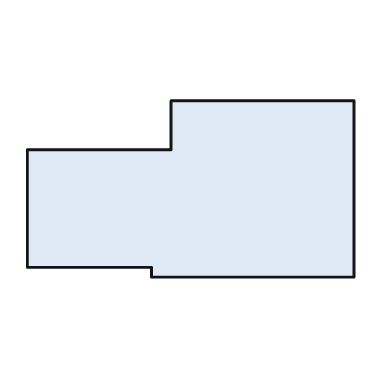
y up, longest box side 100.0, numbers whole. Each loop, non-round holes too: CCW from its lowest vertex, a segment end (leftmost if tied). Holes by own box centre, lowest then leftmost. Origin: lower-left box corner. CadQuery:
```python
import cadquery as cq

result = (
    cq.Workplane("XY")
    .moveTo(38.0, 0.0)
    .lineTo(100.0, 0.0)
    .lineTo(100.0, 54.0)
    .lineTo(44.0, 54.0)
    .lineTo(44.0, 39.0)
    .lineTo(0.0, 39.0)
    .lineTo(0.0, 3.0)
    .lineTo(38.0, 3.0)
    .close()
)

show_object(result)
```